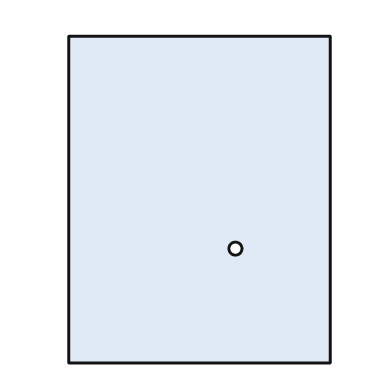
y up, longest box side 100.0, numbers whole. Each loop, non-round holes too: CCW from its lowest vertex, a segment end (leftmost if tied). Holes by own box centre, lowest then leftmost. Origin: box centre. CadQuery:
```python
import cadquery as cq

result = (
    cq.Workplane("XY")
    .moveTo(-40.0, -50.0)
    .lineTo(40.0, -50.0)
    .lineTo(40.0, 50.0)
    .lineTo(-40.0, 50.0)
    .close()
    .moveTo(11.0, -15.0)
    .circle(2.0)
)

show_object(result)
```